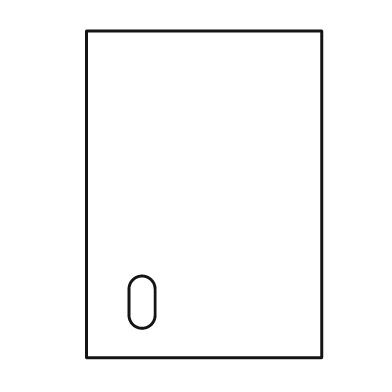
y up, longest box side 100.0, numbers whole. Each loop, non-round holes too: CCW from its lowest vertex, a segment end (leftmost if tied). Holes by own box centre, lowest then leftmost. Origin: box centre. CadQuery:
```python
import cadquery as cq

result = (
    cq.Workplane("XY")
    .moveTo(-36.0, -50.0)
    .lineTo(36.0, -50.0)
    .lineTo(36.0, 50.0)
    .lineTo(-36.0, 50.0)
    .close()
    .moveTo(-23.0, -37.0)
    .threePointArc((-19.0, -41.0), (-15.0, -37.0))
    .lineTo(-15.0, -29.0)
    .threePointArc((-19.0, -25.0), (-23.0, -29.0))
    .close()
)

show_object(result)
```